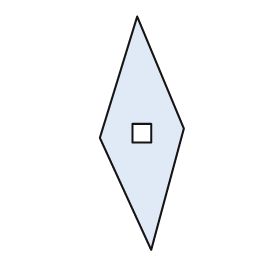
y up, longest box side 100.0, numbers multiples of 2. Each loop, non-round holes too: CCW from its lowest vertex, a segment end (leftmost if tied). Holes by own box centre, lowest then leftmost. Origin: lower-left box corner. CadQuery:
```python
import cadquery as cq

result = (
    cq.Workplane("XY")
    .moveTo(22.0, 0.0)
    .lineTo(36.0, 52.0)
    .lineTo(16.0, 100.0)
    .lineTo(0.0, 48.0)
    .close()
    .moveTo(14.0, 46.0)
    .lineTo(22.0, 46.0)
    .lineTo(22.0, 54.0)
    .lineTo(14.0, 54.0)
    .close()
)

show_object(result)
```